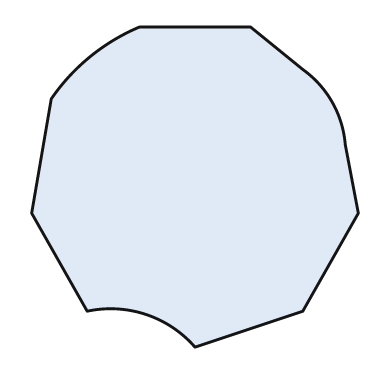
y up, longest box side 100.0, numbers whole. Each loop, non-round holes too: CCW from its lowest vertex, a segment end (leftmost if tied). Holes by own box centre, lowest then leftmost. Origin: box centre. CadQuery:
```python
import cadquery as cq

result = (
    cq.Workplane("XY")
    .moveTo(0.0, -49.0)
    .lineTo(33.0, -38.0)
    .lineTo(50.0, -8.0)
    .lineTo(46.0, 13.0)
    .threePointArc((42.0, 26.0), (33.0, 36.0))
    .lineTo(17.0, 49.0)
    .lineTo(-17.0, 49.0)
    .threePointArc((-32.0, 40.0), (-44.0, 27.0))
    .lineTo(-50.0, -8.0)
    .lineTo(-33.0, -38.0)
    .threePointArc((-15.0, -39.0), (0.0, -49.0))
    .close()
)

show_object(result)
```